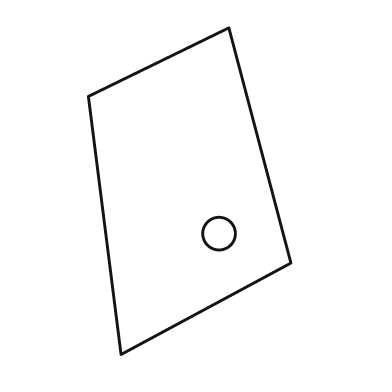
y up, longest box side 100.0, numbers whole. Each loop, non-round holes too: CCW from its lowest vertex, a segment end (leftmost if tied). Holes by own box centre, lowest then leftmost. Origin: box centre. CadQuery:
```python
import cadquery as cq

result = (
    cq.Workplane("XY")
    .moveTo(-21.0, -50.0)
    .lineTo(31.0, -22.0)
    .lineTo(12.0, 50.0)
    .lineTo(-31.0, 29.0)
    .close()
    .moveTo(9.0, -13.0)
    .circle(5.0)
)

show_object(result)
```